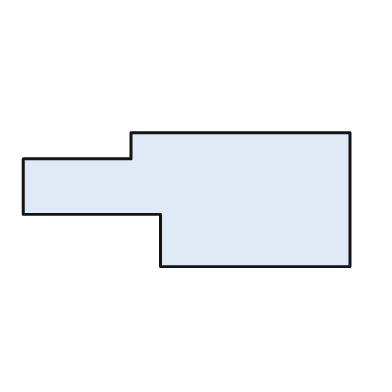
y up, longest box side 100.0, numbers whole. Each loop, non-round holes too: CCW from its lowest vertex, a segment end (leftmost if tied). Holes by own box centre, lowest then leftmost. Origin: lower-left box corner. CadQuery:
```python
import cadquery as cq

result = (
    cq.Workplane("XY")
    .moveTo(42.0, 0.0)
    .lineTo(100.0, 0.0)
    .lineTo(100.0, 41.0)
    .lineTo(33.0, 41.0)
    .lineTo(33.0, 33.0)
    .lineTo(0.0, 33.0)
    .lineTo(0.0, 16.0)
    .lineTo(42.0, 16.0)
    .close()
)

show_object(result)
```